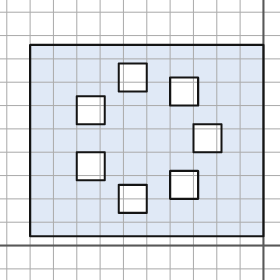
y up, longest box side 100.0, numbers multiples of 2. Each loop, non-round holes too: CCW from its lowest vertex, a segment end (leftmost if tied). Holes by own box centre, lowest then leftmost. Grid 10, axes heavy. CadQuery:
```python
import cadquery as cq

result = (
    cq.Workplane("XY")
    .moveTo(-100.0, 4.0)
    .lineTo(0.0, 4.0)
    .lineTo(0.0, 86.0)
    .lineTo(-100.0, 86.0)
    .close()
    .moveTo(-62.0, 14.0)
    .lineTo(-50.0, 14.0)
    .lineTo(-50.0, 26.0)
    .lineTo(-62.0, 26.0)
    .close()
    .moveTo(-40.0, 20.0)
    .lineTo(-28.0, 20.0)
    .lineTo(-28.0, 32.0)
    .lineTo(-40.0, 32.0)
    .close()
    .moveTo(-80.0, 28.0)
    .lineTo(-68.0, 28.0)
    .lineTo(-68.0, 40.0)
    .lineTo(-80.0, 40.0)
    .close()
    .moveTo(-30.0, 40.0)
    .lineTo(-18.0, 40.0)
    .lineTo(-18.0, 52.0)
    .lineTo(-30.0, 52.0)
    .close()
    .moveTo(-80.0, 52.0)
    .lineTo(-68.0, 52.0)
    .lineTo(-68.0, 64.0)
    .lineTo(-80.0, 64.0)
    .close()
    .moveTo(-40.0, 60.0)
    .lineTo(-28.0, 60.0)
    .lineTo(-28.0, 72.0)
    .lineTo(-40.0, 72.0)
    .close()
    .moveTo(-62.0, 66.0)
    .lineTo(-50.0, 66.0)
    .lineTo(-50.0, 78.0)
    .lineTo(-62.0, 78.0)
    .close()
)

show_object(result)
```